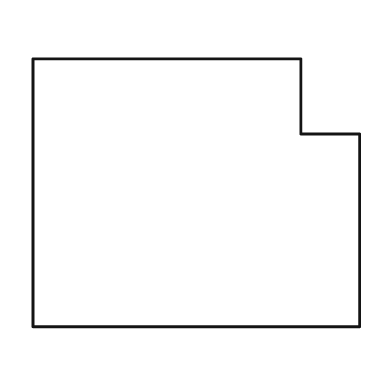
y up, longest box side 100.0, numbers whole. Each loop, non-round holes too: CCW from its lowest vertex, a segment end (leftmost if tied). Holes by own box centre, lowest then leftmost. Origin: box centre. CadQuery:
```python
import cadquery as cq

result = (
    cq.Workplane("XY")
    .moveTo(-50.0, -41.0)
    .lineTo(50.0, -41.0)
    .lineTo(50.0, 18.0)
    .lineTo(32.0, 18.0)
    .lineTo(32.0, 41.0)
    .lineTo(-50.0, 41.0)
    .close()
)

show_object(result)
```